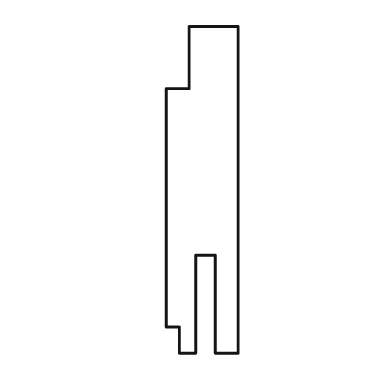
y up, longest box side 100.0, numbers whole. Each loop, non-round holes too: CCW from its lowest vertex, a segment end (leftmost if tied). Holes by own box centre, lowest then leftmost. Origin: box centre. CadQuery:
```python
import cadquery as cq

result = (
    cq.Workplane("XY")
    .moveTo(-7.0, -50.0)
    .lineTo(-2.0, -50.0)
    .lineTo(-2.0, -20.0)
    .lineTo(4.0, -20.0)
    .lineTo(4.0, -50.0)
    .lineTo(11.0, -50.0)
    .lineTo(11.0, 50.0)
    .lineTo(-4.0, 50.0)
    .lineTo(-4.0, 31.0)
    .lineTo(-11.0, 31.0)
    .lineTo(-11.0, -42.0)
    .lineTo(-7.0, -42.0)
    .close()
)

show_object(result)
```